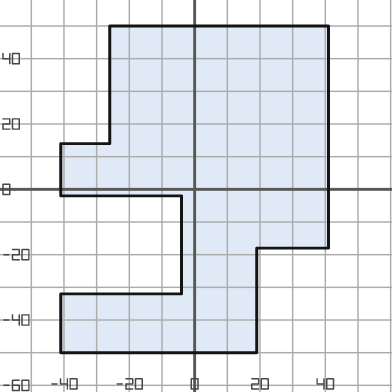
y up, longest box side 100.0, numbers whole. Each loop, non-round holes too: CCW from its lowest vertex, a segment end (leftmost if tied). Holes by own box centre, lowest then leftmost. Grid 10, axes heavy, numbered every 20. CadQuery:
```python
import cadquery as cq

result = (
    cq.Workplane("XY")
    .moveTo(-41.0, -50.0)
    .lineTo(19.0, -50.0)
    .lineTo(19.0, -18.0)
    .lineTo(41.0, -18.0)
    .lineTo(41.0, 50.0)
    .lineTo(-26.0, 50.0)
    .lineTo(-26.0, 14.0)
    .lineTo(-41.0, 14.0)
    .lineTo(-41.0, -2.0)
    .lineTo(-4.0, -2.0)
    .lineTo(-4.0, -32.0)
    .lineTo(-41.0, -32.0)
    .close()
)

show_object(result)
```